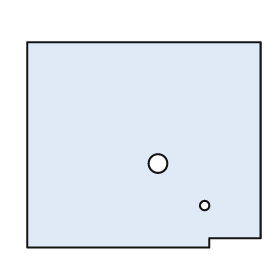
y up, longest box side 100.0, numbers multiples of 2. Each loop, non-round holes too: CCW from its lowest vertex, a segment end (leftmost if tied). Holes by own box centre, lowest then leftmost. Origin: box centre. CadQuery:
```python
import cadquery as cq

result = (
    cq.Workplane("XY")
    .moveTo(-50.0, -44.0)
    .lineTo(28.0, -44.0)
    .lineTo(28.0, -40.0)
    .lineTo(50.0, -40.0)
    .lineTo(50.0, 44.0)
    .lineTo(-50.0, 44.0)
    .close()
    .moveTo(26.0, -26.0)
    .circle(2.0)
    .moveTo(6.0, -8.0)
    .circle(4.0)
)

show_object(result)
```